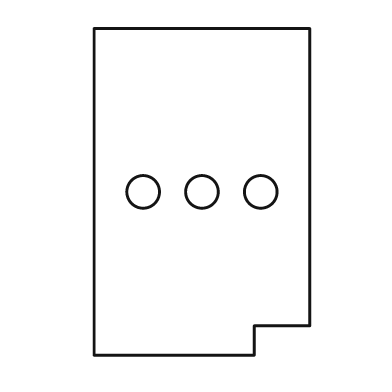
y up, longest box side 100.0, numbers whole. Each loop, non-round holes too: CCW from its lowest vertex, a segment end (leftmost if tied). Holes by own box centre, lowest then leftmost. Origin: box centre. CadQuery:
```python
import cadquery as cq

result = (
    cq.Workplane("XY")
    .moveTo(-33.0, -50.0)
    .lineTo(16.0, -50.0)
    .lineTo(16.0, -41.0)
    .lineTo(33.0, -41.0)
    .lineTo(33.0, 50.0)
    .lineTo(-33.0, 50.0)
    .close()
    .moveTo(-18.0, 0.0)
    .circle(5.0)
    .moveTo(0.0, 0.0)
    .circle(5.0)
    .moveTo(18.0, 0.0)
    .circle(5.0)
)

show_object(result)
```